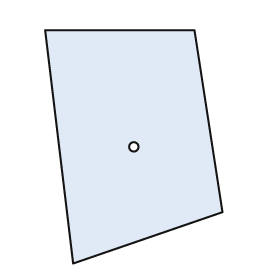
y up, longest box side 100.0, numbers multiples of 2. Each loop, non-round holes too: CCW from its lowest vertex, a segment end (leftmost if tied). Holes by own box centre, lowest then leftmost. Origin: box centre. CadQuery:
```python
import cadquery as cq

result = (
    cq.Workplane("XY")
    .moveTo(-26.0, -50.0)
    .lineTo(38.0, -28.0)
    .lineTo(26.0, 50.0)
    .lineTo(-38.0, 50.0)
    .close()
    .moveTo(0.0, 0.0)
    .circle(2.0)
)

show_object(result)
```